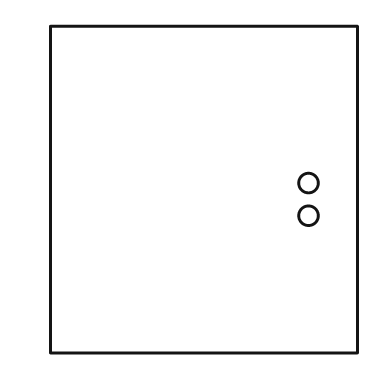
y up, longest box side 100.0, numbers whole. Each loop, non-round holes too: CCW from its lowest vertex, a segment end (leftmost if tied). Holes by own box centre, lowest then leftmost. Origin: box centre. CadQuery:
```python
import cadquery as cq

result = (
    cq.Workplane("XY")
    .moveTo(-47.0, -50.0)
    .lineTo(47.0, -50.0)
    .lineTo(47.0, 50.0)
    .lineTo(-47.0, 50.0)
    .close()
    .moveTo(32.0, -8.0)
    .circle(3.0)
    .moveTo(32.0, 2.0)
    .circle(3.0)
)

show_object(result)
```